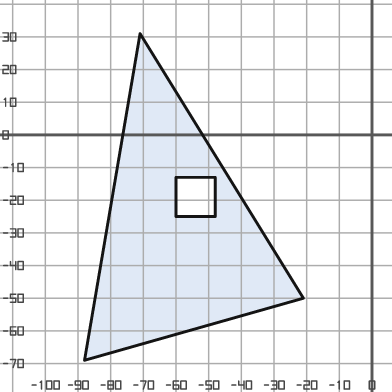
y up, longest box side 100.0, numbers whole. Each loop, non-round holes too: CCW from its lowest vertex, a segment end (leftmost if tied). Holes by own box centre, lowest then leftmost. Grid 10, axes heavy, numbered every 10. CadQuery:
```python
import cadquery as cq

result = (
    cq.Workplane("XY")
    .moveTo(-88.0, -69.0)
    .lineTo(-21.0, -50.0)
    .lineTo(-71.0, 31.0)
    .close()
    .moveTo(-60.0, -25.0)
    .lineTo(-48.0, -25.0)
    .lineTo(-48.0, -13.0)
    .lineTo(-60.0, -13.0)
    .close()
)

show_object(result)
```